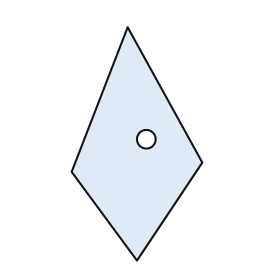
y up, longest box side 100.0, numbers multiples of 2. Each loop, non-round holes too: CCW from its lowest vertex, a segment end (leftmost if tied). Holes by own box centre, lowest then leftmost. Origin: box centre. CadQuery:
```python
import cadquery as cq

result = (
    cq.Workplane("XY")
    .moveTo(0.0, -50.0)
    .lineTo(28.0, -8.0)
    .lineTo(-4.0, 50.0)
    .lineTo(-28.0, -12.0)
    .close()
    .moveTo(4.0, 2.0)
    .circle(4.0)
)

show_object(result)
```